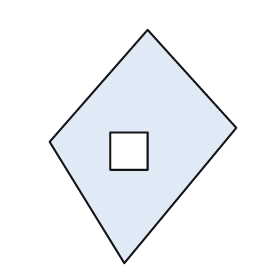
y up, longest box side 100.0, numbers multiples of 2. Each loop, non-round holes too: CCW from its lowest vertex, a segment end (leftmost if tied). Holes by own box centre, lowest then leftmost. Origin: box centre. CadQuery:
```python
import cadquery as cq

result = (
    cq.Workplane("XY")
    .moveTo(-8.0, -50.0)
    .lineTo(40.0, 8.0)
    .lineTo(2.0, 50.0)
    .lineTo(-40.0, 2.0)
    .close()
    .moveTo(-14.0, -10.0)
    .lineTo(2.0, -10.0)
    .lineTo(2.0, 6.0)
    .lineTo(-14.0, 6.0)
    .close()
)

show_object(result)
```